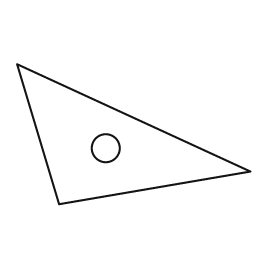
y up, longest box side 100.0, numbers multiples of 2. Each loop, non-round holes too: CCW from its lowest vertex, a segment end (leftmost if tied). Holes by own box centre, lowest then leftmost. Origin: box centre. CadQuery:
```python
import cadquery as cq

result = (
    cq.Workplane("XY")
    .moveTo(-32.0, -30.0)
    .lineTo(50.0, -16.0)
    .lineTo(-50.0, 30.0)
    .close()
    .moveTo(-12.0, -6.0)
    .circle(6.0)
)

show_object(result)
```